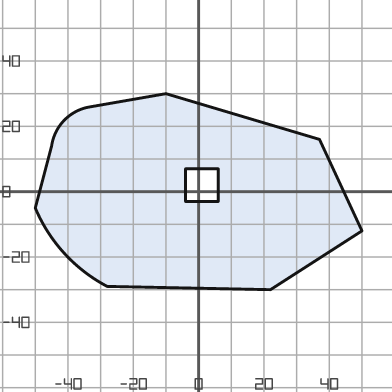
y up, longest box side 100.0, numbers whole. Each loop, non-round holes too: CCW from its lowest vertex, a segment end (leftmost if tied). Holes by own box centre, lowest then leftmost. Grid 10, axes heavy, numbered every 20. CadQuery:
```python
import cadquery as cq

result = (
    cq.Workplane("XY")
    .moveTo(22.0, -30.0)
    .lineTo(50.0, -12.0)
    .lineTo(37.0, 16.0)
    .lineTo(-10.0, 30.0)
    .lineTo(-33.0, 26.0)
    .threePointArc((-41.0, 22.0), (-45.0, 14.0))
    .lineTo(-50.0, -5.0)
    .threePointArc((-41.0, -19.0), (-28.0, -29.0))
    .close()
    .moveTo(-4.0, -3.0)
    .lineTo(6.0, -3.0)
    .lineTo(6.0, 7.0)
    .lineTo(-4.0, 7.0)
    .close()
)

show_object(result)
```